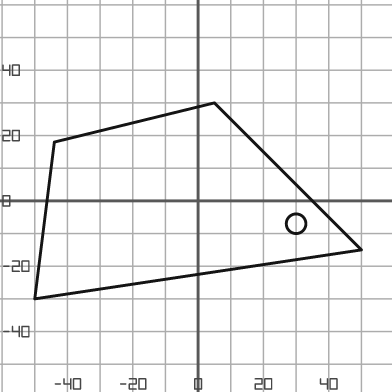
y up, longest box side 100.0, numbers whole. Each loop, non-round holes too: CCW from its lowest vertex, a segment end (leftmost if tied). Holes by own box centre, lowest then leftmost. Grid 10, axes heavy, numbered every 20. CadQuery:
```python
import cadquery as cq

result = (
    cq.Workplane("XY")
    .moveTo(-50.0, -30.0)
    .lineTo(50.0, -15.0)
    .lineTo(5.0, 30.0)
    .lineTo(-44.0, 18.0)
    .close()
    .moveTo(30.0, -7.0)
    .circle(3.0)
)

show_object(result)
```